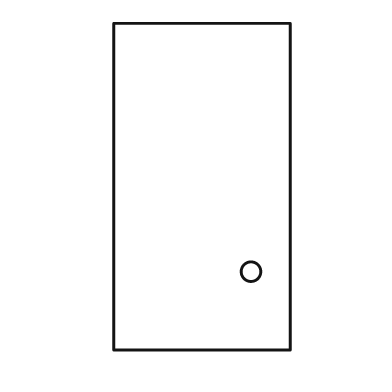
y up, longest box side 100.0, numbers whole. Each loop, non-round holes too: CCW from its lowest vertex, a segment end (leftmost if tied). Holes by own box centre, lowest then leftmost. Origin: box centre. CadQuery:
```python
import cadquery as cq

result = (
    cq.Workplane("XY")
    .moveTo(-27.0, -50.0)
    .lineTo(27.0, -50.0)
    .lineTo(27.0, 50.0)
    .lineTo(-27.0, 50.0)
    .close()
    .moveTo(15.0, -26.0)
    .circle(3.0)
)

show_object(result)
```